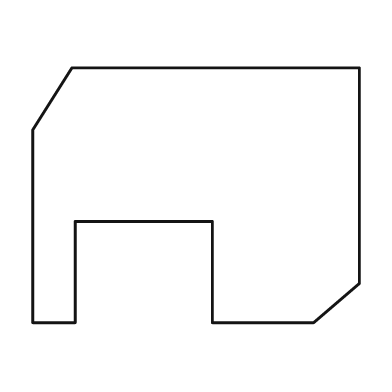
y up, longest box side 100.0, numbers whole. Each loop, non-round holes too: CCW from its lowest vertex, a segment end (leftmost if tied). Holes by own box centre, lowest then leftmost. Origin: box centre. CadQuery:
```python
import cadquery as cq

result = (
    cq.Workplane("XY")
    .moveTo(-50.0, -39.0)
    .lineTo(-37.0, -39.0)
    .lineTo(-37.0, -8.0)
    .lineTo(5.0, -8.0)
    .lineTo(5.0, -39.0)
    .lineTo(36.0, -39.0)
    .lineTo(50.0, -27.0)
    .lineTo(50.0, 39.0)
    .lineTo(-38.0, 39.0)
    .lineTo(-50.0, 20.0)
    .close()
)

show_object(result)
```